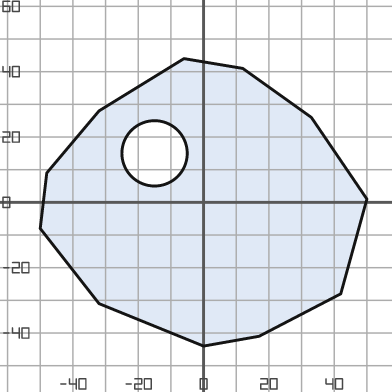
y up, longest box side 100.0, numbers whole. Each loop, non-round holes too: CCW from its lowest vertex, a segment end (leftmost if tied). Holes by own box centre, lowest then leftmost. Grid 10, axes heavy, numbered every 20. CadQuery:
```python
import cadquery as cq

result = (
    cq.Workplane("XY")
    .moveTo(0.0, -44.0)
    .lineTo(17.0, -41.0)
    .lineTo(42.0, -28.0)
    .lineTo(50.0, 1.0)
    .lineTo(33.0, 26.0)
    .lineTo(12.0, 41.0)
    .lineTo(-6.0, 44.0)
    .lineTo(-32.0, 28.0)
    .lineTo(-48.0, 9.0)
    .lineTo(-50.0, -8.0)
    .lineTo(-32.0, -31.0)
    .close()
    .moveTo(-15.0, 15.0)
    .circle(10.0)
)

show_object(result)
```